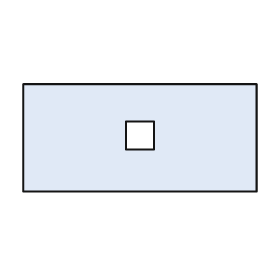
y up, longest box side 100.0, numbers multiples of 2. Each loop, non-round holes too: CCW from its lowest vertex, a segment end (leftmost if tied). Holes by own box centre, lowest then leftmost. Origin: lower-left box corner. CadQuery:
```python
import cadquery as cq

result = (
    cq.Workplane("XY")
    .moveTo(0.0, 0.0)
    .lineTo(100.0, 0.0)
    .lineTo(100.0, 46.0)
    .lineTo(0.0, 46.0)
    .close()
    .moveTo(44.0, 18.0)
    .lineTo(56.0, 18.0)
    .lineTo(56.0, 30.0)
    .lineTo(44.0, 30.0)
    .close()
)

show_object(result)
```